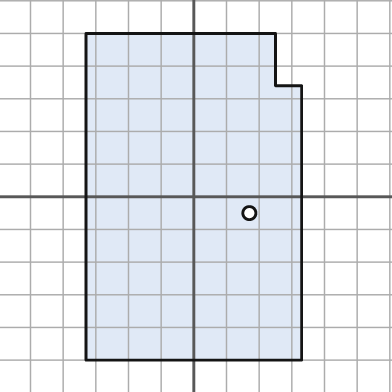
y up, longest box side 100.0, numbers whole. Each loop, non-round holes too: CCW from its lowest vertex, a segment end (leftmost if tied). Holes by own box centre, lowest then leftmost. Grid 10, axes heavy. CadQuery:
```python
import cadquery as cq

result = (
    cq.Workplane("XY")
    .moveTo(-33.0, -50.0)
    .lineTo(33.0, -50.0)
    .lineTo(33.0, 34.0)
    .lineTo(25.0, 34.0)
    .lineTo(25.0, 50.0)
    .lineTo(-33.0, 50.0)
    .close()
    .moveTo(17.0, -5.0)
    .circle(2.0)
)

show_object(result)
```